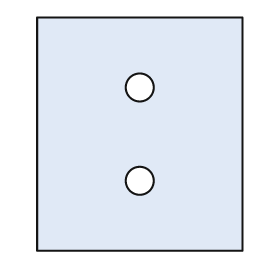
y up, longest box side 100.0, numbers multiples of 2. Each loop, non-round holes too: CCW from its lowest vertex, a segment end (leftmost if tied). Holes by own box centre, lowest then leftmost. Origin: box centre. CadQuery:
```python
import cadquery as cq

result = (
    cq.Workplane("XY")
    .moveTo(-44.0, -50.0)
    .lineTo(44.0, -50.0)
    .lineTo(44.0, 50.0)
    .lineTo(-44.0, 50.0)
    .close()
    .moveTo(0.0, -20.0)
    .circle(6.0)
    .moveTo(0.0, 20.0)
    .circle(6.0)
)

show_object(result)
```